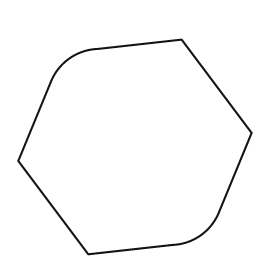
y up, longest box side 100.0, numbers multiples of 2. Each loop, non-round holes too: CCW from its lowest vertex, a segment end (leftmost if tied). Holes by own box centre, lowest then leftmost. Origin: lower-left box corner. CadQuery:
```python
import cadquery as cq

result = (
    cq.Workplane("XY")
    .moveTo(30.0, 0.0)
    .lineTo(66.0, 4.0)
    .threePointArc((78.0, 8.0), (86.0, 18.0))
    .lineTo(100.0, 52.0)
    .lineTo(70.0, 92.0)
    .lineTo(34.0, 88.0)
    .threePointArc((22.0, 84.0), (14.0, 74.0))
    .lineTo(0.0, 40.0)
    .close()
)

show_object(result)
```